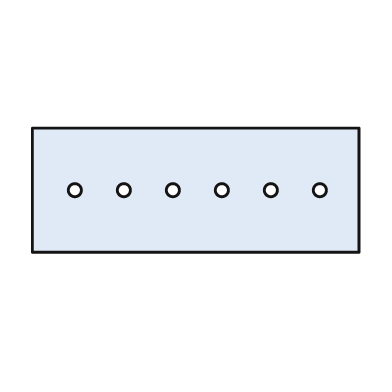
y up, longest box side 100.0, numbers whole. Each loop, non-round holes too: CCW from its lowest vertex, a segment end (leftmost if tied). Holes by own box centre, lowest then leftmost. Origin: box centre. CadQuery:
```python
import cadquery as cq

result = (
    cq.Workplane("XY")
    .moveTo(-50.0, -19.0)
    .lineTo(50.0, -19.0)
    .lineTo(50.0, 19.0)
    .lineTo(-50.0, 19.0)
    .close()
    .moveTo(-37.0, 0.0)
    .circle(2.0)
    .moveTo(-22.0, 0.0)
    .circle(2.0)
    .moveTo(-7.0, 0.0)
    .circle(2.0)
    .moveTo(8.0, 0.0)
    .circle(2.0)
    .moveTo(23.0, 0.0)
    .circle(2.0)
    .moveTo(38.0, 0.0)
    .circle(2.0)
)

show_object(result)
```